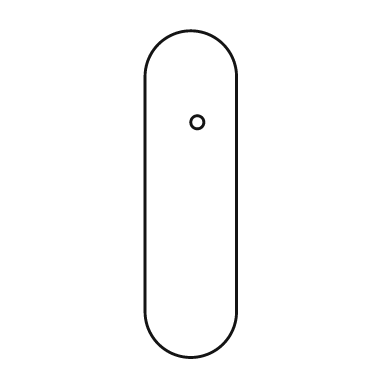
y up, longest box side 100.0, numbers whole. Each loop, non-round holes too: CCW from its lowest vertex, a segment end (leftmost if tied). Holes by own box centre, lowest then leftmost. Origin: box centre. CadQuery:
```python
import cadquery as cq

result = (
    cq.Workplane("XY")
    .moveTo(-14.0, -36.0)
    .threePointArc((0.0, -50.0), (14.0, -36.0))
    .lineTo(14.0, 36.0)
    .threePointArc((0.0, 50.0), (-14.0, 36.0))
    .close()
    .moveTo(2.0, 22.0)
    .circle(2.0)
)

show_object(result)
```